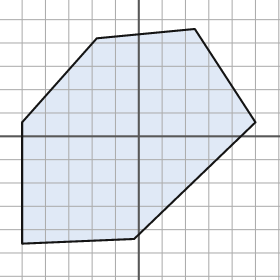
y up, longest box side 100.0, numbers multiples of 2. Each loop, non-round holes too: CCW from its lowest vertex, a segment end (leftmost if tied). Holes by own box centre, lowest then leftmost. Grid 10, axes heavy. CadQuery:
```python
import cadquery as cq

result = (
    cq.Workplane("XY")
    .moveTo(-50.0, -46.0)
    .lineTo(-2.0, -44.0)
    .lineTo(50.0, 6.0)
    .lineTo(24.0, 46.0)
    .lineTo(-18.0, 42.0)
    .lineTo(-50.0, 6.0)
    .close()
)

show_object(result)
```